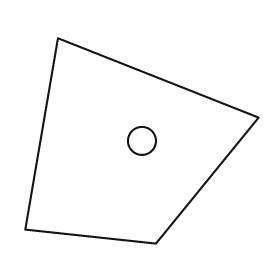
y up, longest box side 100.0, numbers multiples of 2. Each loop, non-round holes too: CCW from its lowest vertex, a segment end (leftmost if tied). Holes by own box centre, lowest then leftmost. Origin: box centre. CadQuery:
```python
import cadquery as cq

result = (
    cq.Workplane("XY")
    .moveTo(6.0, -44.0)
    .lineTo(50.0, 10.0)
    .lineTo(-36.0, 44.0)
    .lineTo(-50.0, -38.0)
    .close()
    .moveTo(0.0, 0.0)
    .circle(6.0)
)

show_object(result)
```